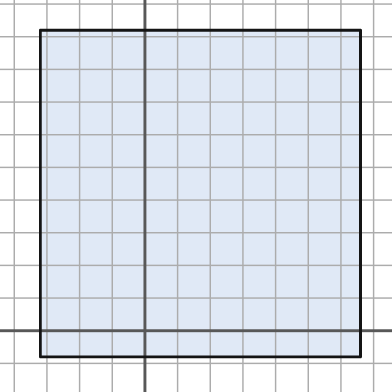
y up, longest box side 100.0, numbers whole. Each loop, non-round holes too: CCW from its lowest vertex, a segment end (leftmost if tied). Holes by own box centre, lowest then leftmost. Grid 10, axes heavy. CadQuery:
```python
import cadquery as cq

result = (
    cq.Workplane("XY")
    .moveTo(-32.0, -8.0)
    .lineTo(66.0, -8.0)
    .lineTo(66.0, 92.0)
    .lineTo(-32.0, 92.0)
    .close()
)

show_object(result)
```